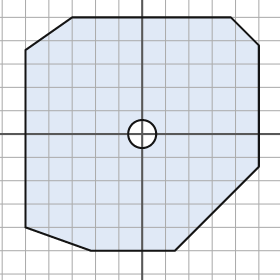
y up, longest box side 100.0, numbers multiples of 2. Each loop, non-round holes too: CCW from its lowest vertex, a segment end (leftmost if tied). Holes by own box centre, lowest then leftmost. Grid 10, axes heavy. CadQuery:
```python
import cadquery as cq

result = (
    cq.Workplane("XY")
    .moveTo(-22.0, -50.0)
    .lineTo(14.0, -50.0)
    .lineTo(50.0, -14.0)
    .lineTo(50.0, 38.0)
    .lineTo(38.0, 50.0)
    .lineTo(-30.0, 50.0)
    .lineTo(-50.0, 36.0)
    .lineTo(-50.0, -40.0)
    .close()
    .moveTo(0.0, 0.0)
    .circle(6.0)
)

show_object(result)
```